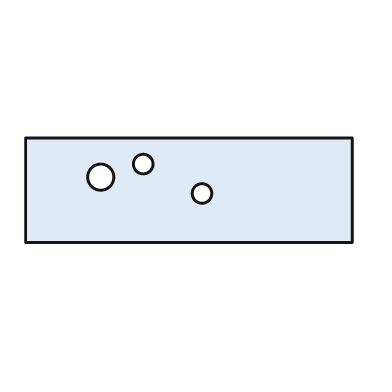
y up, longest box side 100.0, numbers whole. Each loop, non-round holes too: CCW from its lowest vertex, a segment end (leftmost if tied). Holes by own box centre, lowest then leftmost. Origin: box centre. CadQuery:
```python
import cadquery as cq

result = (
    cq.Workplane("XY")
    .moveTo(-50.0, -16.0)
    .lineTo(50.0, -16.0)
    .lineTo(50.0, 16.0)
    .lineTo(-50.0, 16.0)
    .close()
    .moveTo(4.0, -1.0)
    .circle(3.0)
    .moveTo(-27.0, 4.0)
    .circle(4.0)
    .moveTo(-14.0, 8.0)
    .circle(3.0)
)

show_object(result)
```